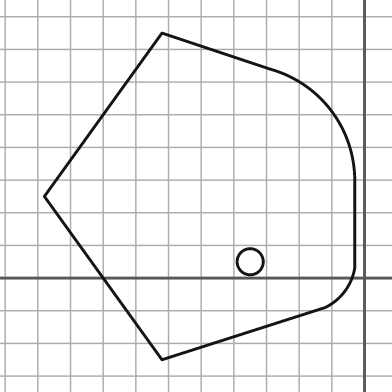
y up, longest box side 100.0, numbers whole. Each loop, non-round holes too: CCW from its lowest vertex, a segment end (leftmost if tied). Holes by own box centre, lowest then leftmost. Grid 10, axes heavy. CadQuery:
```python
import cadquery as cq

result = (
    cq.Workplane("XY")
    .moveTo(-62.0, -25.0)
    .lineTo(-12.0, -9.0)
    .threePointArc((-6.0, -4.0), (-3.0, 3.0))
    .lineTo(-3.0, 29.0)
    .threePointArc((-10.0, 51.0), (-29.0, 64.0))
    .lineTo(-62.0, 75.0)
    .lineTo(-98.0, 25.0)
    .close()
    .moveTo(-35.0, 5.0)
    .circle(4.0)
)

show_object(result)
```